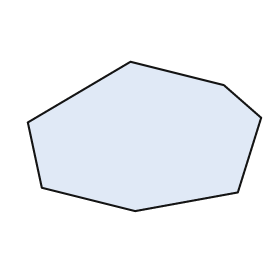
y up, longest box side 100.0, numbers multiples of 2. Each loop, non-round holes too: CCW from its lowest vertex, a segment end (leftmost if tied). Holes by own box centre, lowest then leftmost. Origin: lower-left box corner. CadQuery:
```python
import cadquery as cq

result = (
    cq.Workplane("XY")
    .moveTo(46.0, 0.0)
    .lineTo(90.0, 8.0)
    .lineTo(100.0, 40.0)
    .lineTo(84.0, 54.0)
    .lineTo(44.0, 64.0)
    .lineTo(0.0, 38.0)
    .lineTo(6.0, 10.0)
    .close()
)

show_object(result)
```